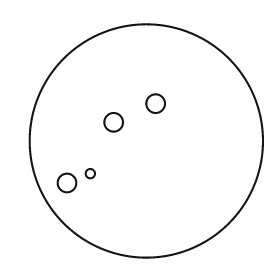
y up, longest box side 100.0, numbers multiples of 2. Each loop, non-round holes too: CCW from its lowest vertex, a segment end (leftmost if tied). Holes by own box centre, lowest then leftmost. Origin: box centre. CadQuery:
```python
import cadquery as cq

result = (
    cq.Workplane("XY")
    .moveTo(0.0, 0.0)
    .circle(50.0)
    .moveTo(-34.0, -18.0)
    .circle(4.0)
    .moveTo(-24.0, -14.0)
    .circle(2.0)
    .moveTo(-14.0, 8.0)
    .circle(4.0)
    .moveTo(4.0, 16.0)
    .circle(4.0)
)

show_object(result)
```